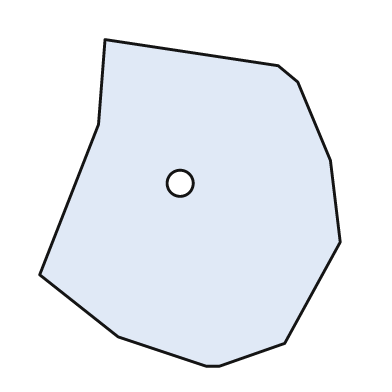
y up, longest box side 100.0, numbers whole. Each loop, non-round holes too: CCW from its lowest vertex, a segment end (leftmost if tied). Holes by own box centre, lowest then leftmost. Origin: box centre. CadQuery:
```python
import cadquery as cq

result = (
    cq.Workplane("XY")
    .moveTo(5.0, -50.0)
    .lineTo(9.0, -50.0)
    .lineTo(29.0, -43.0)
    .lineTo(46.0, -12.0)
    .lineTo(43.0, 13.0)
    .lineTo(33.0, 37.0)
    .lineTo(27.0, 42.0)
    .lineTo(-26.0, 50.0)
    .lineTo(-28.0, 24.0)
    .lineTo(-46.0, -22.0)
    .lineTo(-22.0, -41.0)
    .close()
    .moveTo(-3.0, 6.0)
    .circle(4.0)
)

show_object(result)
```